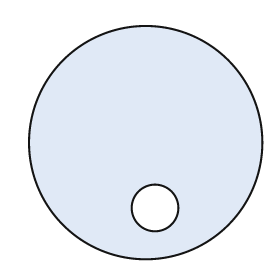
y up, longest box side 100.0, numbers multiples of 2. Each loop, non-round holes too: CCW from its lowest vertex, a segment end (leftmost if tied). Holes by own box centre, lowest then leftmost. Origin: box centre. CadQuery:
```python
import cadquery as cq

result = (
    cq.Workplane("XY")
    .moveTo(0.0, 0.0)
    .circle(50.0)
    .moveTo(4.0, -28.0)
    .circle(10.0)
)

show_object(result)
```